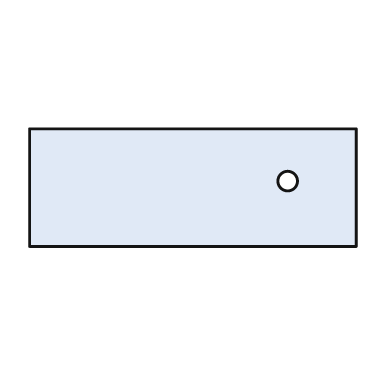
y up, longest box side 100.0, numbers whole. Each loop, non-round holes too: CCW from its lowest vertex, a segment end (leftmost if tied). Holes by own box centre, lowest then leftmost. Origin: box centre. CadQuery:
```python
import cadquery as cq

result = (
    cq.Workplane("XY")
    .moveTo(-50.0, -18.0)
    .lineTo(50.0, -18.0)
    .lineTo(50.0, 18.0)
    .lineTo(-50.0, 18.0)
    .close()
    .moveTo(29.0, 2.0)
    .circle(3.0)
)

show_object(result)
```